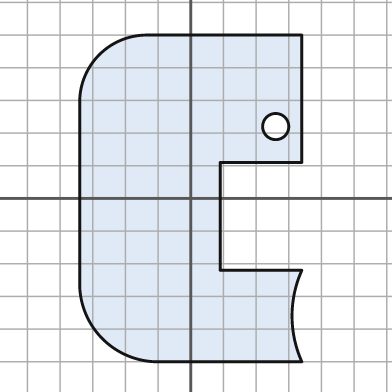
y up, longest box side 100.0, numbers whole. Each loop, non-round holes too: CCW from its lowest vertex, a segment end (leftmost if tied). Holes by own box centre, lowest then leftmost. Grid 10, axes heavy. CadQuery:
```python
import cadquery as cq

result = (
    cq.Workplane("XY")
    .moveTo(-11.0, -50.0)
    .lineTo(34.0, -50.0)
    .threePointArc((31.0, -36.0), (34.0, -22.0))
    .lineTo(9.0, -22.0)
    .lineTo(9.0, 11.0)
    .lineTo(34.0, 11.0)
    .lineTo(34.0, 50.0)
    .lineTo(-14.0, 50.0)
    .threePointArc((-28.0, 44.0), (-34.0, 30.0))
    .lineTo(-34.0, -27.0)
    .threePointArc((-27.0, -43.0), (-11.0, -50.0))
    .close()
    .moveTo(26.0, 22.0)
    .circle(4.0)
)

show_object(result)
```